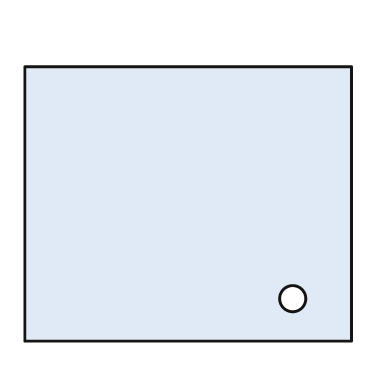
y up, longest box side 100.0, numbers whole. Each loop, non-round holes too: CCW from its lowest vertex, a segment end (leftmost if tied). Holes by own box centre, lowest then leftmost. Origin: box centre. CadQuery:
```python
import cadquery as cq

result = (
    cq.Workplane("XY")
    .moveTo(-50.0, -42.0)
    .lineTo(50.0, -42.0)
    .lineTo(50.0, 42.0)
    .lineTo(-50.0, 42.0)
    .close()
    .moveTo(32.0, -29.0)
    .circle(4.0)
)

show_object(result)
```